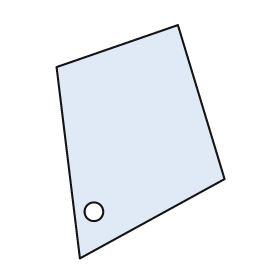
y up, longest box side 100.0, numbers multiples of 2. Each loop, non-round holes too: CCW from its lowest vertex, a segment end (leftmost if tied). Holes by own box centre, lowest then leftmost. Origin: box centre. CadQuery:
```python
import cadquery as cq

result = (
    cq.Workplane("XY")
    .moveTo(-26.0, -50.0)
    .lineTo(36.0, -16.0)
    .lineTo(16.0, 50.0)
    .lineTo(-36.0, 32.0)
    .close()
    .moveTo(-20.0, -30.0)
    .circle(4.0)
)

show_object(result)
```